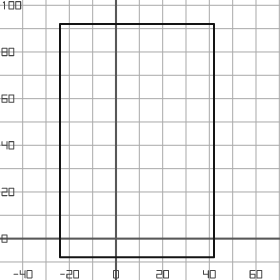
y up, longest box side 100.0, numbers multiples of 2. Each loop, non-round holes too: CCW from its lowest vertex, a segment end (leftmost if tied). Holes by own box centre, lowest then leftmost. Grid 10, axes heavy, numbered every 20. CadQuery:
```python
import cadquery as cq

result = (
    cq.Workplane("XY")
    .moveTo(-24.0, -8.0)
    .lineTo(42.0, -8.0)
    .lineTo(42.0, 92.0)
    .lineTo(-24.0, 92.0)
    .close()
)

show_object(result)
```